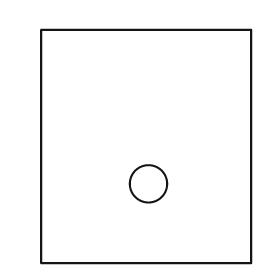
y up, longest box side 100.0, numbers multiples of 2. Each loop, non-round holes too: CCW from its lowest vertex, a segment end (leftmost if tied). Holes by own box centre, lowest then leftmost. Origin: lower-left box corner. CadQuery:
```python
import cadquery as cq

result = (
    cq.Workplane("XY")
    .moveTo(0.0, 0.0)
    .lineTo(90.0, 0.0)
    .lineTo(90.0, 100.0)
    .lineTo(0.0, 100.0)
    .close()
    .moveTo(46.0, 34.0)
    .circle(8.0)
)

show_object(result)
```